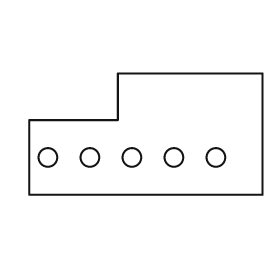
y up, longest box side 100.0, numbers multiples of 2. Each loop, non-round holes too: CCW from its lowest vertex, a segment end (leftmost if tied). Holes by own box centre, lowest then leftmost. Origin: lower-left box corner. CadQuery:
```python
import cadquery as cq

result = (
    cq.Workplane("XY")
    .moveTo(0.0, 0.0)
    .lineTo(100.0, 0.0)
    .lineTo(100.0, 52.0)
    .lineTo(38.0, 52.0)
    .lineTo(38.0, 32.0)
    .lineTo(0.0, 32.0)
    .close()
    .moveTo(8.0, 16.0)
    .circle(4.0)
    .moveTo(26.0, 16.0)
    .circle(4.0)
    .moveTo(44.0, 16.0)
    .circle(4.0)
    .moveTo(62.0, 16.0)
    .circle(4.0)
    .moveTo(80.0, 16.0)
    .circle(4.0)
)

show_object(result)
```